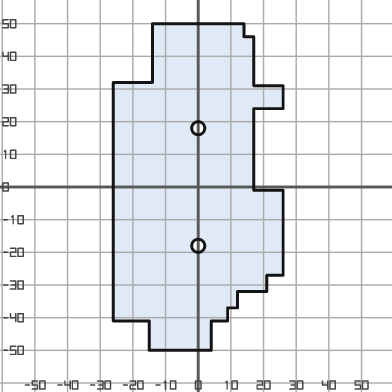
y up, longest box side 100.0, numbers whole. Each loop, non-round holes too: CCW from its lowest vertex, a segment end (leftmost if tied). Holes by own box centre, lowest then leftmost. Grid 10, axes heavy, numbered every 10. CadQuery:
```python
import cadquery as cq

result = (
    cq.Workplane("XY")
    .moveTo(-15.0, -50.0)
    .lineTo(4.0, -50.0)
    .lineTo(4.0, -41.0)
    .lineTo(9.0, -41.0)
    .lineTo(9.0, -37.0)
    .lineTo(12.0, -37.0)
    .lineTo(12.0, -32.0)
    .lineTo(21.0, -32.0)
    .lineTo(21.0, -27.0)
    .lineTo(26.0, -27.0)
    .lineTo(26.0, -1.0)
    .lineTo(17.0, -1.0)
    .lineTo(17.0, 24.0)
    .lineTo(26.0, 24.0)
    .lineTo(26.0, 31.0)
    .lineTo(17.0, 31.0)
    .lineTo(17.0, 46.0)
    .lineTo(14.0, 46.0)
    .lineTo(14.0, 50.0)
    .lineTo(-14.0, 50.0)
    .lineTo(-14.0, 32.0)
    .lineTo(-26.0, 32.0)
    .lineTo(-26.0, -41.0)
    .lineTo(-15.0, -41.0)
    .close()
    .moveTo(0.0, -18.0)
    .circle(2.0)
    .moveTo(0.0, 18.0)
    .circle(2.0)
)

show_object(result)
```